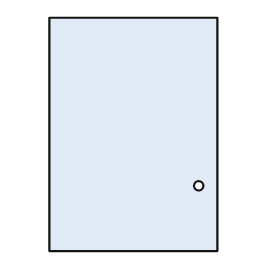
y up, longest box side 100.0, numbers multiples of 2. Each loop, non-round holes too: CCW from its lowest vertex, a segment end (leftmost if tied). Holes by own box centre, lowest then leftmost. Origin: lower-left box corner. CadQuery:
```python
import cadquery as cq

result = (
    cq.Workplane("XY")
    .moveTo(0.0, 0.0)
    .lineTo(72.0, 0.0)
    .lineTo(72.0, 100.0)
    .lineTo(0.0, 100.0)
    .close()
    .moveTo(64.0, 28.0)
    .circle(2.0)
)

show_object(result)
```